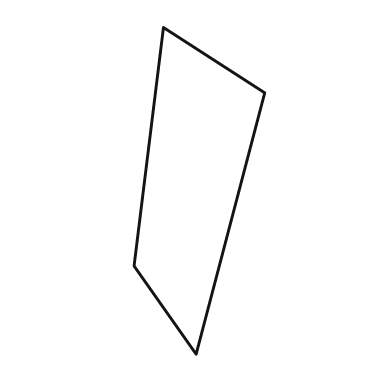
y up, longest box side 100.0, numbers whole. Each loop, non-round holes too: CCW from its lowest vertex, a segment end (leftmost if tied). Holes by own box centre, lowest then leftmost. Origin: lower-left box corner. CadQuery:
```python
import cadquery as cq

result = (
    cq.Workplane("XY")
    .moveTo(19.0, 0.0)
    .lineTo(40.0, 80.0)
    .lineTo(9.0, 100.0)
    .lineTo(0.0, 27.0)
    .close()
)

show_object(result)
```